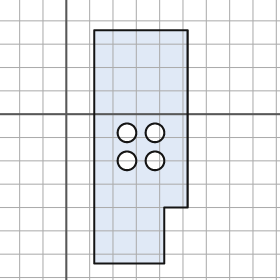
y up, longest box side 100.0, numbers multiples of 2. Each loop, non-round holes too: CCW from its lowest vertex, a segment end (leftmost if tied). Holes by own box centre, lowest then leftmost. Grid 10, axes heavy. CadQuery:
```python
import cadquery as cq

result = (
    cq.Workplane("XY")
    .moveTo(12.0, -64.0)
    .lineTo(42.0, -64.0)
    .lineTo(42.0, -40.0)
    .lineTo(52.0, -40.0)
    .lineTo(52.0, 36.0)
    .lineTo(12.0, 36.0)
    .close()
    .moveTo(26.0, -20.0)
    .circle(4.0)
    .moveTo(38.0, -20.0)
    .circle(4.0)
    .moveTo(26.0, -8.0)
    .circle(4.0)
    .moveTo(38.0, -8.0)
    .circle(4.0)
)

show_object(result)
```